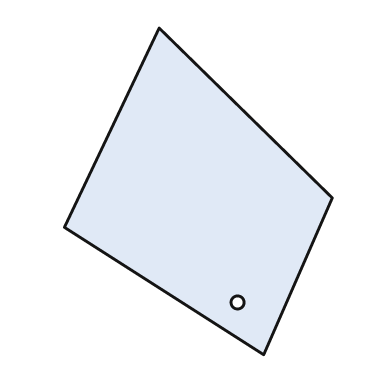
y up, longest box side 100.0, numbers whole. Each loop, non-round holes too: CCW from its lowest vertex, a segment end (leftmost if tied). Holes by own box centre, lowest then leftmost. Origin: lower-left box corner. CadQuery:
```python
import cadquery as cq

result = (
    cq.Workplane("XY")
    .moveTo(61.0, 0.0)
    .lineTo(82.0, 48.0)
    .lineTo(29.0, 100.0)
    .lineTo(0.0, 39.0)
    .close()
    .moveTo(53.0, 16.0)
    .circle(2.0)
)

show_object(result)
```